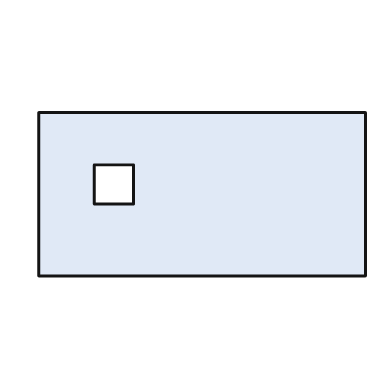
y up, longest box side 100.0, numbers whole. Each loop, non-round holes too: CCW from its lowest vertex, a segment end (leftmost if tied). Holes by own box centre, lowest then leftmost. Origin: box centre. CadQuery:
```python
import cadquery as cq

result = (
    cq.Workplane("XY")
    .moveTo(-50.0, -25.0)
    .lineTo(50.0, -25.0)
    .lineTo(50.0, 25.0)
    .lineTo(-50.0, 25.0)
    .close()
    .moveTo(-33.0, -3.0)
    .lineTo(-21.0, -3.0)
    .lineTo(-21.0, 9.0)
    .lineTo(-33.0, 9.0)
    .close()
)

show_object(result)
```